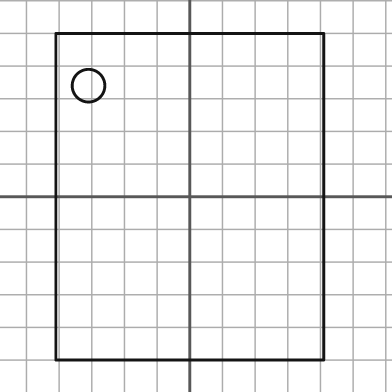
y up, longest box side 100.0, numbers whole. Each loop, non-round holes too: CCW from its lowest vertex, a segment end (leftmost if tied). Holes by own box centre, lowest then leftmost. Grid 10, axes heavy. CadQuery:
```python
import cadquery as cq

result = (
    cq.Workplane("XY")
    .moveTo(-41.0, -50.0)
    .lineTo(41.0, -50.0)
    .lineTo(41.0, 50.0)
    .lineTo(-41.0, 50.0)
    .close()
    .moveTo(-31.0, 34.0)
    .circle(5.0)
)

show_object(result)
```